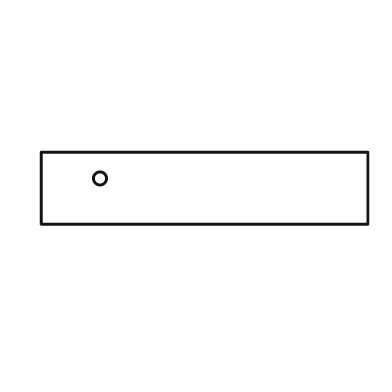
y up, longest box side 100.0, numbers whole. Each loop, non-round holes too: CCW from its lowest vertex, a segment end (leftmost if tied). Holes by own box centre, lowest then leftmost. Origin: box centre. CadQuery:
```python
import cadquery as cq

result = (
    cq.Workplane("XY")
    .moveTo(-50.0, -11.0)
    .lineTo(50.0, -11.0)
    .lineTo(50.0, 11.0)
    .lineTo(-50.0, 11.0)
    .close()
    .moveTo(-32.0, 3.0)
    .circle(2.0)
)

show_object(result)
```